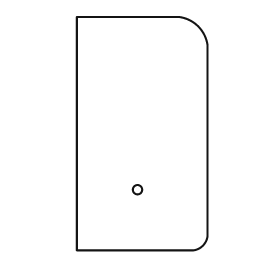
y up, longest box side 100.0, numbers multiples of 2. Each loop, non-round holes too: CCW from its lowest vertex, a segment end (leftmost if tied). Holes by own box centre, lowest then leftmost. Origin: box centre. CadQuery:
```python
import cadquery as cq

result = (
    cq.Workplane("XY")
    .moveTo(-28.0, -50.0)
    .lineTo(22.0, -50.0)
    .threePointArc((26.0, -48.0), (28.0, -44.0))
    .lineTo(28.0, 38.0)
    .threePointArc((24.0, 46.0), (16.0, 50.0))
    .lineTo(-28.0, 50.0)
    .close()
    .moveTo(-2.0, -24.0)
    .circle(2.0)
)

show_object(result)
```